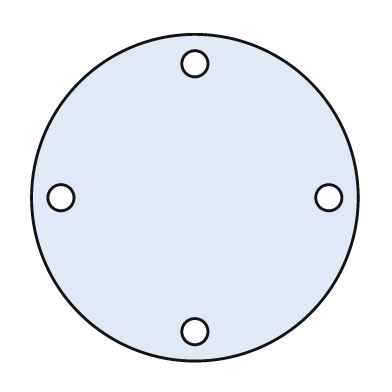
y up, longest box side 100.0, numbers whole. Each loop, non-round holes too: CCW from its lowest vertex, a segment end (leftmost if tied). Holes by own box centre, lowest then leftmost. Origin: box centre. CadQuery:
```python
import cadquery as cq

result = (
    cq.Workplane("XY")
    .moveTo(0.0, 0.0)
    .circle(50.0)
    .moveTo(0.0, -41.0)
    .circle(4.0)
    .moveTo(-41.0, 0.0)
    .circle(4.0)
    .moveTo(41.0, 0.0)
    .circle(4.0)
    .moveTo(0.0, 41.0)
    .circle(4.0)
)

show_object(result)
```